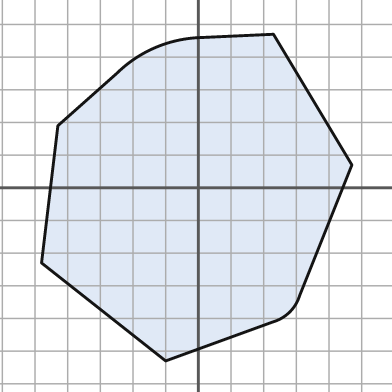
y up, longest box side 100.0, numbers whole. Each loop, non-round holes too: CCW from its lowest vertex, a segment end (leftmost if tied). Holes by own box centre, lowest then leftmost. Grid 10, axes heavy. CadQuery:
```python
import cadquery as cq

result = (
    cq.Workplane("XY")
    .moveTo(-10.0, -53.0)
    .lineTo(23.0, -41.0)
    .threePointArc((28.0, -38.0), (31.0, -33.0))
    .lineTo(47.0, 7.0)
    .lineTo(23.0, 47.0)
    .lineTo(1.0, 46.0)
    .threePointArc((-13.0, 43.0), (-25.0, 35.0))
    .lineTo(-43.0, 19.0)
    .lineTo(-48.0, -23.0)
    .close()
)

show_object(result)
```